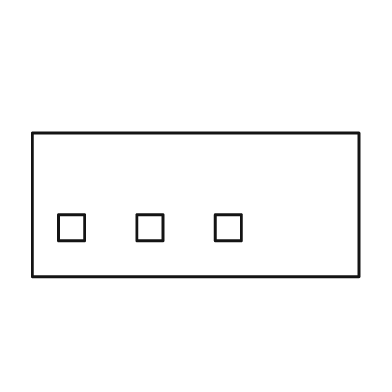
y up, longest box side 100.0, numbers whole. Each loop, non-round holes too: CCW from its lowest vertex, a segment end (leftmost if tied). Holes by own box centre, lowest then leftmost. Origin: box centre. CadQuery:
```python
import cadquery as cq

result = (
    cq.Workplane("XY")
    .moveTo(-50.0, -22.0)
    .lineTo(50.0, -22.0)
    .lineTo(50.0, 22.0)
    .lineTo(-50.0, 22.0)
    .close()
    .moveTo(-42.0, -11.0)
    .lineTo(-34.0, -11.0)
    .lineTo(-34.0, -3.0)
    .lineTo(-42.0, -3.0)
    .close()
    .moveTo(-18.0, -11.0)
    .lineTo(-10.0, -11.0)
    .lineTo(-10.0, -3.0)
    .lineTo(-18.0, -3.0)
    .close()
    .moveTo(6.0, -11.0)
    .lineTo(14.0, -11.0)
    .lineTo(14.0, -3.0)
    .lineTo(6.0, -3.0)
    .close()
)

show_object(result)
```